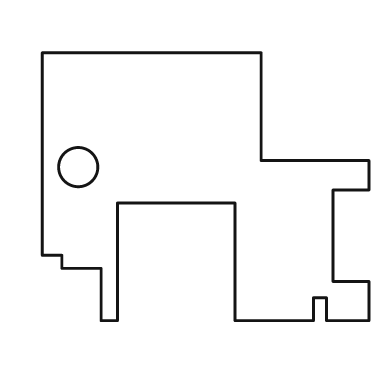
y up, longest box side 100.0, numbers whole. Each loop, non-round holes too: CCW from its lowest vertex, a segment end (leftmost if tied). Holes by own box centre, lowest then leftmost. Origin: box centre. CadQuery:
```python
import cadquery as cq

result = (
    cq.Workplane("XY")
    .moveTo(-32.0, -41.0)
    .lineTo(-27.0, -41.0)
    .lineTo(-27.0, -5.0)
    .lineTo(9.0, -5.0)
    .lineTo(9.0, -41.0)
    .lineTo(33.0, -41.0)
    .lineTo(33.0, -34.0)
    .lineTo(37.0, -34.0)
    .lineTo(37.0, -41.0)
    .lineTo(50.0, -41.0)
    .lineTo(50.0, -29.0)
    .lineTo(39.0, -29.0)
    .lineTo(39.0, -1.0)
    .lineTo(50.0, -1.0)
    .lineTo(50.0, 8.0)
    .lineTo(17.0, 8.0)
    .lineTo(17.0, 41.0)
    .lineTo(-50.0, 41.0)
    .lineTo(-50.0, -21.0)
    .lineTo(-44.0, -21.0)
    .lineTo(-44.0, -25.0)
    .lineTo(-32.0, -25.0)
    .close()
    .moveTo(-39.0, 6.0)
    .circle(6.0)
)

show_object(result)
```